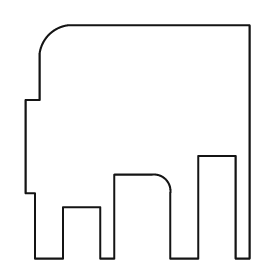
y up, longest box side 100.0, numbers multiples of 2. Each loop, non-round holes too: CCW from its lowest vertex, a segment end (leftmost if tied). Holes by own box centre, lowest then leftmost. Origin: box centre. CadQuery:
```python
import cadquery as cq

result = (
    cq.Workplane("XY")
    .moveTo(-44.0, -50.0)
    .lineTo(-32.0, -50.0)
    .lineTo(-32.0, -28.0)
    .lineTo(-16.0, -28.0)
    .lineTo(-16.0, -50.0)
    .lineTo(-10.0, -50.0)
    .lineTo(-10.0, -14.0)
    .lineTo(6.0, -14.0)
    .threePointArc((12.0, -16.0), (14.0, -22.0))
    .lineTo(14.0, -50.0)
    .lineTo(26.0, -50.0)
    .lineTo(26.0, -6.0)
    .lineTo(42.0, -6.0)
    .lineTo(42.0, -50.0)
    .lineTo(48.0, -50.0)
    .lineTo(48.0, 50.0)
    .lineTo(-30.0, 50.0)
    .threePointArc((-38.0, 46.0), (-42.0, 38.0))
    .lineTo(-42.0, 18.0)
    .lineTo(-48.0, 18.0)
    .lineTo(-48.0, -22.0)
    .lineTo(-44.0, -22.0)
    .close()
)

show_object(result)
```